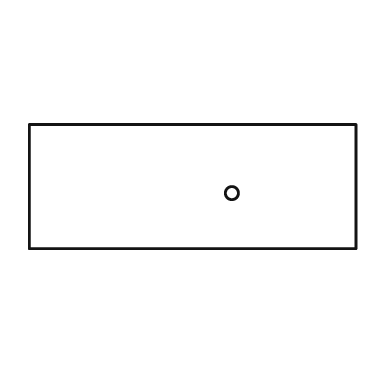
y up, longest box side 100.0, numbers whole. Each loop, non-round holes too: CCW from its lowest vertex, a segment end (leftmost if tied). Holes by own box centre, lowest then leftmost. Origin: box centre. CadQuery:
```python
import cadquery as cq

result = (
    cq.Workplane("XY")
    .moveTo(-50.0, -19.0)
    .lineTo(50.0, -19.0)
    .lineTo(50.0, 19.0)
    .lineTo(-50.0, 19.0)
    .close()
    .moveTo(12.0, -2.0)
    .circle(2.0)
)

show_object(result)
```